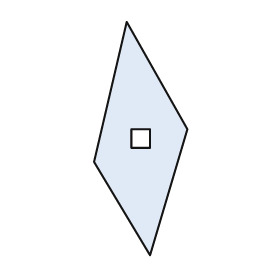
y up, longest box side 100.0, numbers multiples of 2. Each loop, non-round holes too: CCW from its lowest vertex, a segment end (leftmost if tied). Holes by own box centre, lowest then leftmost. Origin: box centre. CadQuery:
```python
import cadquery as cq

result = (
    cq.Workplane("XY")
    .moveTo(4.0, -50.0)
    .lineTo(20.0, 4.0)
    .lineTo(-6.0, 50.0)
    .lineTo(-20.0, -10.0)
    .close()
    .moveTo(-4.0, -4.0)
    .lineTo(4.0, -4.0)
    .lineTo(4.0, 4.0)
    .lineTo(-4.0, 4.0)
    .close()
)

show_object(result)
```